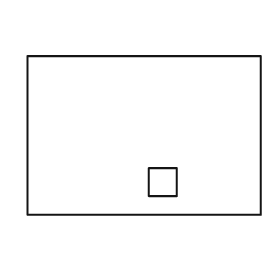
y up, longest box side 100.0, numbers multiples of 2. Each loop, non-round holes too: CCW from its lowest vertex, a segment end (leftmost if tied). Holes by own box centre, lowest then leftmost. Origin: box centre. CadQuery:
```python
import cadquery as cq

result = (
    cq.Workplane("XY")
    .moveTo(-50.0, -34.0)
    .lineTo(50.0, -34.0)
    .lineTo(50.0, 34.0)
    .lineTo(-50.0, 34.0)
    .close()
    .moveTo(2.0, -26.0)
    .lineTo(14.0, -26.0)
    .lineTo(14.0, -14.0)
    .lineTo(2.0, -14.0)
    .close()
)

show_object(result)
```